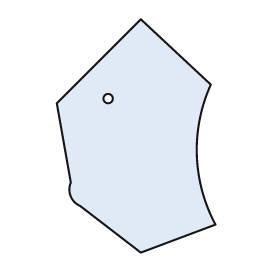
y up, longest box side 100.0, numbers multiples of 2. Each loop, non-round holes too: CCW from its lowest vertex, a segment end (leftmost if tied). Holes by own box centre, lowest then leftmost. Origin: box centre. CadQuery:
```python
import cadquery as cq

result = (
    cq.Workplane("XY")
    .moveTo(2.0, -50.0)
    .lineTo(34.0, -38.0)
    .threePointArc((26.0, -8.0), (32.0, 22.0))
    .lineTo(2.0, 50.0)
    .lineTo(-34.0, 14.0)
    .lineTo(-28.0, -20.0)
    .threePointArc((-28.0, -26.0), (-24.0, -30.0))
    .close()
    .moveTo(-12.0, 16.0)
    .circle(2.0)
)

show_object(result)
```